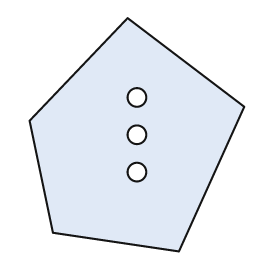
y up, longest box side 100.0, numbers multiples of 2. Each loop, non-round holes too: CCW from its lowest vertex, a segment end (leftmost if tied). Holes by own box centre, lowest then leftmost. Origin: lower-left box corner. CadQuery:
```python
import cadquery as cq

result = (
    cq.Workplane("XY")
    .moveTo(64.0, 0.0)
    .lineTo(92.0, 62.0)
    .lineTo(42.0, 100.0)
    .lineTo(0.0, 56.0)
    .lineTo(10.0, 8.0)
    .close()
    .moveTo(46.0, 34.0)
    .circle(4.0)
    .moveTo(46.0, 50.0)
    .circle(4.0)
    .moveTo(46.0, 66.0)
    .circle(4.0)
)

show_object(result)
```